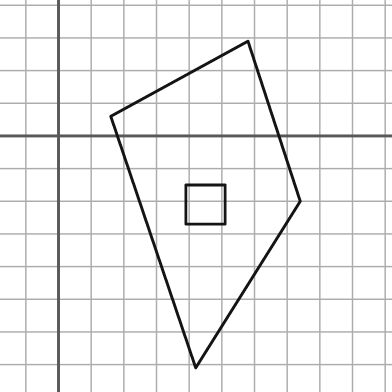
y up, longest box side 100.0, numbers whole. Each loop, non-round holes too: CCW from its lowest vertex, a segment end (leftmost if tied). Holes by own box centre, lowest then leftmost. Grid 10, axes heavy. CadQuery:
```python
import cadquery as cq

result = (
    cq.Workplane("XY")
    .moveTo(42.0, -71.0)
    .lineTo(74.0, -20.0)
    .lineTo(58.0, 29.0)
    .lineTo(16.0, 6.0)
    .close()
    .moveTo(39.0, -27.0)
    .lineTo(51.0, -27.0)
    .lineTo(51.0, -15.0)
    .lineTo(39.0, -15.0)
    .close()
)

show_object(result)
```